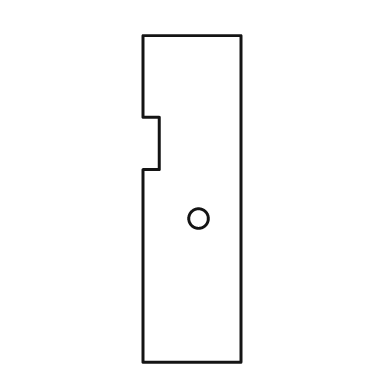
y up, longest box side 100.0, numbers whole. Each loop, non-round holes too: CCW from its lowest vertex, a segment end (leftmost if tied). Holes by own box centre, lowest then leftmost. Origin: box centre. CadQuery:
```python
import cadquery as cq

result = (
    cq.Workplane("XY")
    .moveTo(-15.0, -50.0)
    .lineTo(15.0, -50.0)
    .lineTo(15.0, 50.0)
    .lineTo(-15.0, 50.0)
    .lineTo(-15.0, 25.0)
    .lineTo(-10.0, 25.0)
    .lineTo(-10.0, 9.0)
    .lineTo(-15.0, 9.0)
    .close()
    .moveTo(2.0, -6.0)
    .circle(3.0)
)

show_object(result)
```